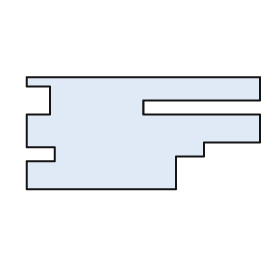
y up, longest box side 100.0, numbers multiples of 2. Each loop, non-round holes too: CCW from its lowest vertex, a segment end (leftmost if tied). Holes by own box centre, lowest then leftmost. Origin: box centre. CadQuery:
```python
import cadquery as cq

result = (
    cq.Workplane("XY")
    .moveTo(-50.0, -24.0)
    .lineTo(14.0, -24.0)
    .lineTo(14.0, -10.0)
    .lineTo(26.0, -10.0)
    .lineTo(26.0, -4.0)
    .lineTo(50.0, -4.0)
    .lineTo(50.0, 8.0)
    .lineTo(0.0, 8.0)
    .lineTo(0.0, 14.0)
    .lineTo(50.0, 14.0)
    .lineTo(50.0, 24.0)
    .lineTo(-50.0, 24.0)
    .lineTo(-50.0, 20.0)
    .lineTo(-40.0, 20.0)
    .lineTo(-40.0, 8.0)
    .lineTo(-50.0, 8.0)
    .lineTo(-50.0, -6.0)
    .lineTo(-38.0, -6.0)
    .lineTo(-38.0, -12.0)
    .lineTo(-50.0, -12.0)
    .close()
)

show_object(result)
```